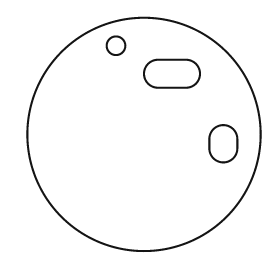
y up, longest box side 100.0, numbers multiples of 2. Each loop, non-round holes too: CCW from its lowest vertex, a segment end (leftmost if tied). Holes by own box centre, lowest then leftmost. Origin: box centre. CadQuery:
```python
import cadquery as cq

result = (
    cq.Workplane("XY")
    .moveTo(0.0, 0.0)
    .circle(50.0)
    .moveTo(28.0, -6.0)
    .threePointArc((34.0, -12.0), (40.0, -6.0))
    .lineTo(40.0, -2.0)
    .threePointArc((34.0, 4.0), (28.0, -2.0))
    .close()
    .moveTo(6.0, 20.0)
    .lineTo(18.0, 20.0)
    .threePointArc((24.0, 26.0), (18.0, 32.0))
    .lineTo(6.0, 32.0)
    .threePointArc((0.0, 26.0), (6.0, 20.0))
    .close()
    .moveTo(-12.0, 38.0)
    .circle(4.0)
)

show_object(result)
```